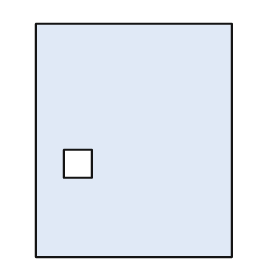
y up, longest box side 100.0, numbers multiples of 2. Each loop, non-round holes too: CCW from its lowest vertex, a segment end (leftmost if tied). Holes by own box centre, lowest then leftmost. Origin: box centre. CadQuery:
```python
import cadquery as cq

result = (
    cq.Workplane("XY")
    .moveTo(-42.0, -50.0)
    .lineTo(42.0, -50.0)
    .lineTo(42.0, 50.0)
    .lineTo(-42.0, 50.0)
    .close()
    .moveTo(-30.0, -16.0)
    .lineTo(-18.0, -16.0)
    .lineTo(-18.0, -4.0)
    .lineTo(-30.0, -4.0)
    .close()
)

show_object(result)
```